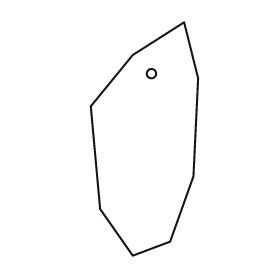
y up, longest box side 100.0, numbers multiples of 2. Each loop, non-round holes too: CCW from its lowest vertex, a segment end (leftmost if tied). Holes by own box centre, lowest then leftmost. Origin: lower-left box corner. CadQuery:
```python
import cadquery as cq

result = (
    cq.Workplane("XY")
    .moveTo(18.0, 0.0)
    .lineTo(34.0, 6.0)
    .lineTo(44.0, 34.0)
    .lineTo(46.0, 76.0)
    .lineTo(40.0, 100.0)
    .lineTo(18.0, 86.0)
    .lineTo(0.0, 64.0)
    .lineTo(4.0, 20.0)
    .close()
    .moveTo(26.0, 78.0)
    .circle(2.0)
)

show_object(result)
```